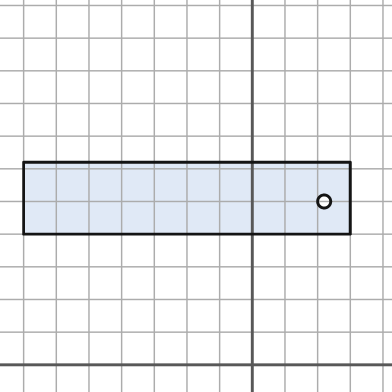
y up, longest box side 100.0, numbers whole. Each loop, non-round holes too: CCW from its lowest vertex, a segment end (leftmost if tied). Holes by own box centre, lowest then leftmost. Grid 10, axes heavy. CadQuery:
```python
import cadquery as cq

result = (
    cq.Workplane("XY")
    .moveTo(-70.0, 40.0)
    .lineTo(30.0, 40.0)
    .lineTo(30.0, 62.0)
    .lineTo(-70.0, 62.0)
    .close()
    .moveTo(22.0, 50.0)
    .circle(2.0)
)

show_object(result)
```